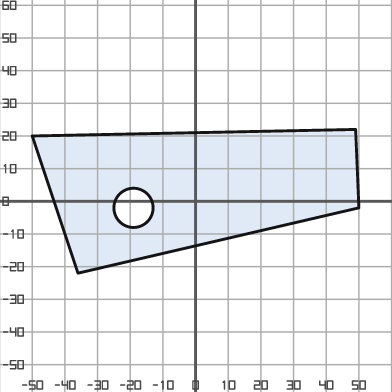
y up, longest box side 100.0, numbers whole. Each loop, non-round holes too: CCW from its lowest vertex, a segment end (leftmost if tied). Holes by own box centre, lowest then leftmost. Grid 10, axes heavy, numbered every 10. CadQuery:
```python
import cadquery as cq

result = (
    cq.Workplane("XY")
    .moveTo(-36.0, -22.0)
    .lineTo(50.0, -2.0)
    .lineTo(49.0, 22.0)
    .lineTo(-50.0, 20.0)
    .close()
    .moveTo(-19.0, -2.0)
    .circle(6.0)
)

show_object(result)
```